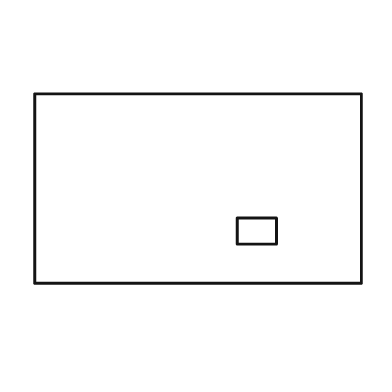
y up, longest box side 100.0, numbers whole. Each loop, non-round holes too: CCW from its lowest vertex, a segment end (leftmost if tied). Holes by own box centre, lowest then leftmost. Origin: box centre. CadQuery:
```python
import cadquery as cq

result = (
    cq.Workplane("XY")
    .moveTo(-50.0, -29.0)
    .lineTo(50.0, -29.0)
    .lineTo(50.0, 29.0)
    .lineTo(-50.0, 29.0)
    .close()
    .moveTo(12.0, -17.0)
    .lineTo(24.0, -17.0)
    .lineTo(24.0, -9.0)
    .lineTo(12.0, -9.0)
    .close()
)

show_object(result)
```